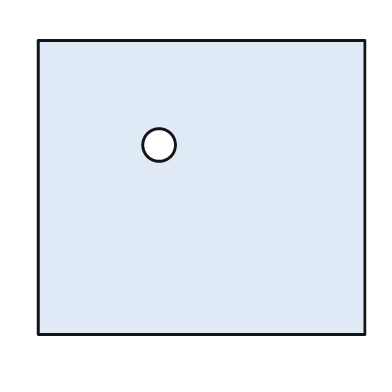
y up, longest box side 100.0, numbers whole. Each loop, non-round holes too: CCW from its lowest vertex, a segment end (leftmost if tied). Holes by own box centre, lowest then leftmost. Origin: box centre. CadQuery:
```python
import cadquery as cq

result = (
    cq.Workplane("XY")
    .moveTo(-50.0, -45.0)
    .lineTo(50.0, -45.0)
    .lineTo(50.0, 45.0)
    .lineTo(-50.0, 45.0)
    .close()
    .moveTo(-13.0, 13.0)
    .circle(5.0)
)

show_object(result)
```